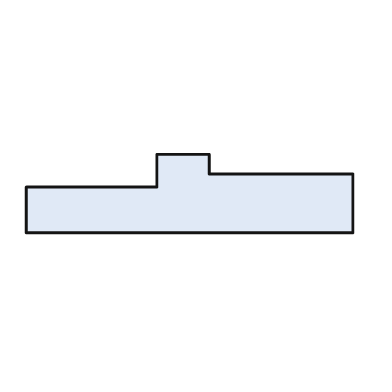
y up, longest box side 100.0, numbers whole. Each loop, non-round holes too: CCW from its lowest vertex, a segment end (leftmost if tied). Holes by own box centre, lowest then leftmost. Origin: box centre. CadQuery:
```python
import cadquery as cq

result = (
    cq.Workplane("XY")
    .moveTo(-50.0, -12.0)
    .lineTo(50.0, -12.0)
    .lineTo(50.0, 6.0)
    .lineTo(6.0, 6.0)
    .lineTo(6.0, 12.0)
    .lineTo(-10.0, 12.0)
    .lineTo(-10.0, 2.0)
    .lineTo(-50.0, 2.0)
    .close()
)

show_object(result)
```